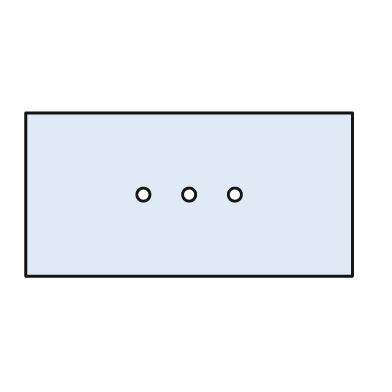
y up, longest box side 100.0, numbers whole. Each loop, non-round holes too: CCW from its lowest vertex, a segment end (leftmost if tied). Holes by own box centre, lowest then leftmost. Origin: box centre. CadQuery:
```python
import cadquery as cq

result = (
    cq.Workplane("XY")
    .moveTo(-50.0, -25.0)
    .lineTo(50.0, -25.0)
    .lineTo(50.0, 25.0)
    .lineTo(-50.0, 25.0)
    .close()
    .moveTo(-14.0, 0.0)
    .circle(2.0)
    .moveTo(0.0, 0.0)
    .circle(2.0)
    .moveTo(14.0, 0.0)
    .circle(2.0)
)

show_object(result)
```